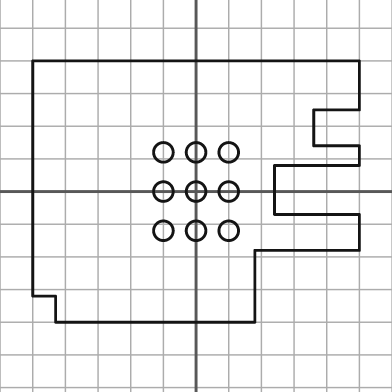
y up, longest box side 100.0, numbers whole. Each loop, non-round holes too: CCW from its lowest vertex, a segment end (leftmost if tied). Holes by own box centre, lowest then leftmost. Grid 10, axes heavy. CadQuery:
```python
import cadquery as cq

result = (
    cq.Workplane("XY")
    .moveTo(-43.0, -40.0)
    .lineTo(18.0, -40.0)
    .lineTo(18.0, -18.0)
    .lineTo(50.0, -18.0)
    .lineTo(50.0, -7.0)
    .lineTo(24.0, -7.0)
    .lineTo(24.0, 8.0)
    .lineTo(50.0, 8.0)
    .lineTo(50.0, 14.0)
    .lineTo(36.0, 14.0)
    .lineTo(36.0, 25.0)
    .lineTo(50.0, 25.0)
    .lineTo(50.0, 40.0)
    .lineTo(-50.0, 40.0)
    .lineTo(-50.0, -32.0)
    .lineTo(-43.0, -32.0)
    .close()
    .moveTo(-10.0, -12.0)
    .circle(3.0)
    .moveTo(0.0, -12.0)
    .circle(3.0)
    .moveTo(10.0, -12.0)
    .circle(3.0)
    .moveTo(-10.0, 0.0)
    .circle(3.0)
    .moveTo(0.0, 0.0)
    .circle(3.0)
    .moveTo(10.0, 0.0)
    .circle(3.0)
    .moveTo(-10.0, 12.0)
    .circle(3.0)
    .moveTo(0.0, 12.0)
    .circle(3.0)
    .moveTo(10.0, 12.0)
    .circle(3.0)
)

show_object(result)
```